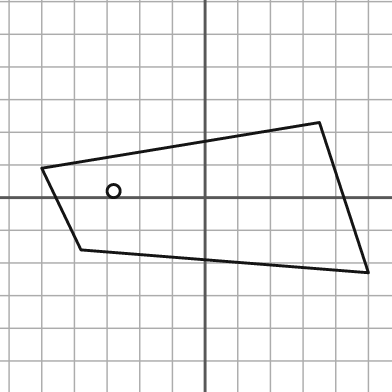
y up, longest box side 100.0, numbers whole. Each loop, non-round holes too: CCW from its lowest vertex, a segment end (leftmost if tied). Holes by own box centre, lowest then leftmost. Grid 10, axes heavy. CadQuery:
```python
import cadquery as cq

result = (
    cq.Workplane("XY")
    .moveTo(50.0, -23.0)
    .lineTo(35.0, 23.0)
    .lineTo(-50.0, 9.0)
    .lineTo(-38.0, -16.0)
    .close()
    .moveTo(-28.0, 2.0)
    .circle(2.0)
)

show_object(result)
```